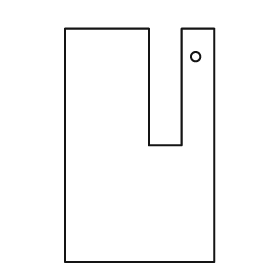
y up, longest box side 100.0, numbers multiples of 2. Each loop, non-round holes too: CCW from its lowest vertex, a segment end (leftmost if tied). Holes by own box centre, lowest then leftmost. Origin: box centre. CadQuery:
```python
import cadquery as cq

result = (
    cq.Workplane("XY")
    .moveTo(-32.0, -50.0)
    .lineTo(32.0, -50.0)
    .lineTo(32.0, 50.0)
    .lineTo(18.0, 50.0)
    .lineTo(18.0, 0.0)
    .lineTo(4.0, 0.0)
    .lineTo(4.0, 50.0)
    .lineTo(-32.0, 50.0)
    .close()
    .moveTo(24.0, 38.0)
    .circle(2.0)
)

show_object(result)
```